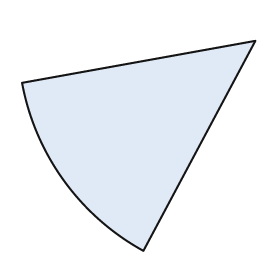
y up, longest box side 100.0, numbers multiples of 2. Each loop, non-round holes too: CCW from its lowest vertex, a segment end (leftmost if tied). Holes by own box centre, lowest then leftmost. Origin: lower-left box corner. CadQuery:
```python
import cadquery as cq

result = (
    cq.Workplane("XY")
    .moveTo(52.0, 0.0)
    .lineTo(100.0, 90.0)
    .lineTo(0.0, 72.0)
    .threePointArc((18.0, 30.0), (52.0, 0.0))
    .close()
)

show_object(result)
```